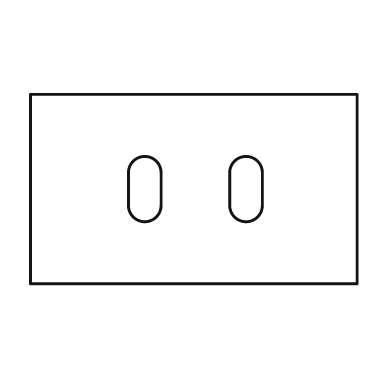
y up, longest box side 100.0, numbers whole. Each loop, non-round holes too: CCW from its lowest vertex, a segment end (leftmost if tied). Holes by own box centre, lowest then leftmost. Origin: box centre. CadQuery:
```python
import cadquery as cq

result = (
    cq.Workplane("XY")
    .moveTo(-50.0, -29.0)
    .lineTo(50.0, -29.0)
    .lineTo(50.0, 29.0)
    .lineTo(-50.0, 29.0)
    .close()
    .moveTo(-20.0, -5.0)
    .threePointArc((-15.0, -10.0), (-10.0, -5.0))
    .lineTo(-10.0, 5.0)
    .threePointArc((-15.0, 10.0), (-20.0, 5.0))
    .close()
    .moveTo(11.0, -5.0)
    .threePointArc((16.0, -10.0), (21.0, -5.0))
    .lineTo(21.0, 5.0)
    .threePointArc((16.0, 10.0), (11.0, 5.0))
    .close()
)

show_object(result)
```